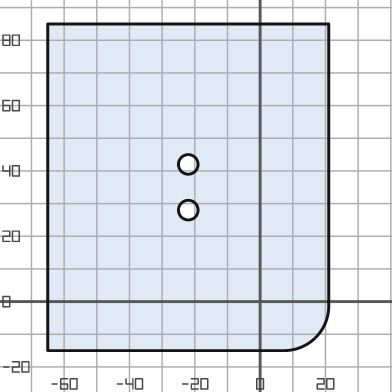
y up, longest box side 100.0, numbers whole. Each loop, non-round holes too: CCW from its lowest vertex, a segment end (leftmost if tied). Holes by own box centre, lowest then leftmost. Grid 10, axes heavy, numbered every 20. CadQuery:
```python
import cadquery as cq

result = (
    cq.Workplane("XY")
    .moveTo(-65.0, -15.0)
    .lineTo(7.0, -15.0)
    .threePointArc((17.0, -11.0), (21.0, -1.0))
    .lineTo(21.0, 85.0)
    .lineTo(-65.0, 85.0)
    .close()
    .moveTo(-22.0, 28.0)
    .circle(3.0)
    .moveTo(-22.0, 42.0)
    .circle(3.0)
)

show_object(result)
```